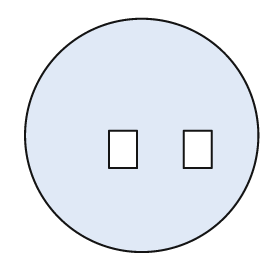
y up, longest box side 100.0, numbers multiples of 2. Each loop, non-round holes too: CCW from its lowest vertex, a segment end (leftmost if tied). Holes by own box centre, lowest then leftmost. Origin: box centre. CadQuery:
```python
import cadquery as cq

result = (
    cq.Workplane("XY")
    .moveTo(0.0, 0.0)
    .circle(50.0)
    .moveTo(-14.0, -14.0)
    .lineTo(-2.0, -14.0)
    .lineTo(-2.0, 2.0)
    .lineTo(-14.0, 2.0)
    .close()
    .moveTo(18.0, -14.0)
    .lineTo(30.0, -14.0)
    .lineTo(30.0, 2.0)
    .lineTo(18.0, 2.0)
    .close()
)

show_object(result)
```